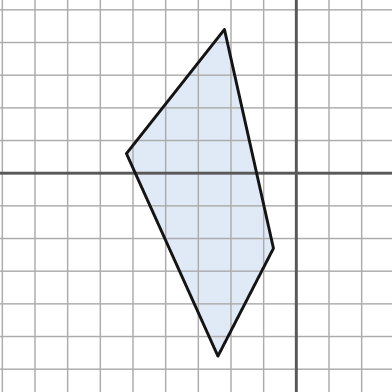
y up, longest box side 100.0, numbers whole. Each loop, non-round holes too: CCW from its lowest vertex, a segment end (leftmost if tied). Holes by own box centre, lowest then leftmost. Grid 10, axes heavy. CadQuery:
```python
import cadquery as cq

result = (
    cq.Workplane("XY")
    .moveTo(-24.0, -56.0)
    .lineTo(-7.0, -23.0)
    .lineTo(-22.0, 44.0)
    .lineTo(-52.0, 6.0)
    .close()
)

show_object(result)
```